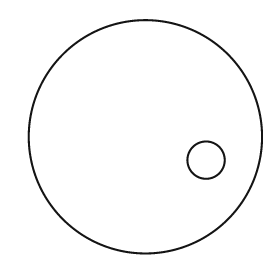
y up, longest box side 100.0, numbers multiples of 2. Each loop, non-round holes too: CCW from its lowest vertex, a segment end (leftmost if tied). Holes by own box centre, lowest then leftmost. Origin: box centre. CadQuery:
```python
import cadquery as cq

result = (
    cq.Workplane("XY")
    .moveTo(0.0, 0.0)
    .circle(50.0)
    .moveTo(26.0, -10.0)
    .circle(8.0)
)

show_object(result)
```